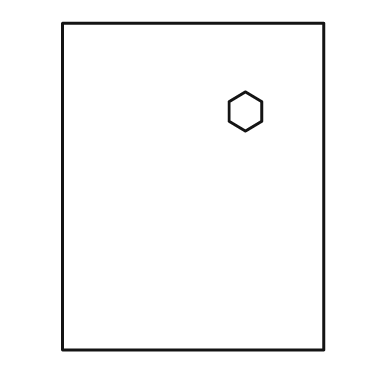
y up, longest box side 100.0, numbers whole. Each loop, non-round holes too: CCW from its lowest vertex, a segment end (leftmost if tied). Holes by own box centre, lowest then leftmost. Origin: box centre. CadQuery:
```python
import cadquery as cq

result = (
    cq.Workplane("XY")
    .moveTo(-40.0, -50.0)
    .lineTo(40.0, -50.0)
    .lineTo(40.0, 50.0)
    .lineTo(-40.0, 50.0)
    .close()
    .moveTo(16.0, 17.0)
    .lineTo(21.0, 20.0)
    .lineTo(21.0, 26.0)
    .lineTo(16.0, 29.0)
    .lineTo(11.0, 26.0)
    .lineTo(11.0, 20.0)
    .close()
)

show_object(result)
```